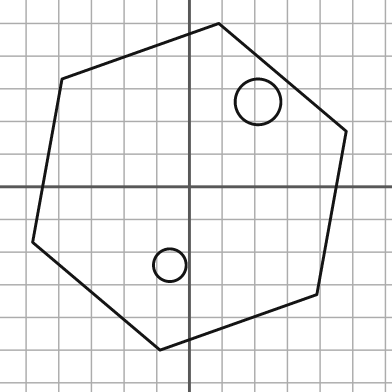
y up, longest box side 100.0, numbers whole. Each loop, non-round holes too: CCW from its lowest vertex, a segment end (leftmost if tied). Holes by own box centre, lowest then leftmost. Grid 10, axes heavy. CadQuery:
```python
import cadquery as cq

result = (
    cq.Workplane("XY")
    .moveTo(-9.0, -50.0)
    .lineTo(39.0, -33.0)
    .lineTo(48.0, 17.0)
    .lineTo(9.0, 50.0)
    .lineTo(-39.0, 33.0)
    .lineTo(-48.0, -17.0)
    .close()
    .moveTo(-6.0, -24.0)
    .circle(5.0)
    .moveTo(21.0, 26.0)
    .circle(7.0)
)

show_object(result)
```